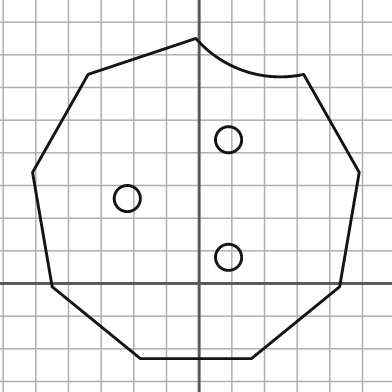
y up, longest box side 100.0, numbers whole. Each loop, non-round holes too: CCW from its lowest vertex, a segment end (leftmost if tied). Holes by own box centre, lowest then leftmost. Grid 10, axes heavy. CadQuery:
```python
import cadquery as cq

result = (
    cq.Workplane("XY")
    .moveTo(-18.0, -23.0)
    .lineTo(16.0, -23.0)
    .lineTo(43.0, -1.0)
    .lineTo(49.0, 34.0)
    .lineTo(32.0, 64.0)
    .threePointArc((14.0, 65.0), (-1.0, 75.0))
    .lineTo(-34.0, 64.0)
    .lineTo(-51.0, 34.0)
    .lineTo(-45.0, -1.0)
    .close()
    .moveTo(9.0, 8.0)
    .circle(4.0)
    .moveTo(-22.0, 26.0)
    .circle(4.0)
    .moveTo(9.0, 44.0)
    .circle(4.0)
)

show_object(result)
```